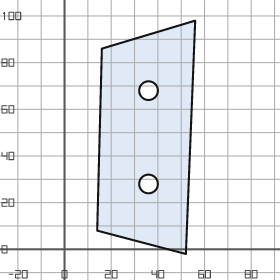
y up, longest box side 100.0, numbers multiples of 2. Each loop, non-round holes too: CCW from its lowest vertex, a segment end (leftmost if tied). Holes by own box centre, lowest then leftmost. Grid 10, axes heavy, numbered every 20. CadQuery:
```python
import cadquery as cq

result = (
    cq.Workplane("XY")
    .moveTo(52.0, -2.0)
    .lineTo(56.0, 98.0)
    .lineTo(16.0, 86.0)
    .lineTo(14.0, 8.0)
    .close()
    .moveTo(36.0, 28.0)
    .circle(4.0)
    .moveTo(36.0, 68.0)
    .circle(4.0)
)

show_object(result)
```